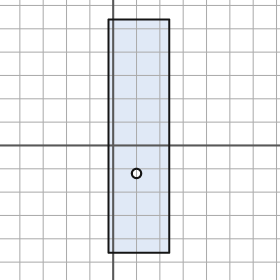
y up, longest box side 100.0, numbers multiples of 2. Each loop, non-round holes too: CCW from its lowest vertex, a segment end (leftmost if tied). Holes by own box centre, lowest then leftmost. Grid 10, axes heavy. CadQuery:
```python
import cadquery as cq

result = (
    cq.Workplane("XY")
    .moveTo(-2.0, -46.0)
    .lineTo(24.0, -46.0)
    .lineTo(24.0, 54.0)
    .lineTo(-2.0, 54.0)
    .close()
    .moveTo(10.0, -12.0)
    .circle(2.0)
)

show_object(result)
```